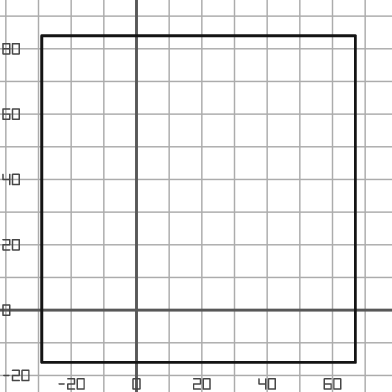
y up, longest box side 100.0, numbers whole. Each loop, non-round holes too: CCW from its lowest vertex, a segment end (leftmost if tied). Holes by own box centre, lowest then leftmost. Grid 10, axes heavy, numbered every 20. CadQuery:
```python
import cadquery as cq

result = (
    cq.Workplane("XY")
    .moveTo(-29.0, -16.0)
    .lineTo(67.0, -16.0)
    .lineTo(67.0, 84.0)
    .lineTo(-29.0, 84.0)
    .close()
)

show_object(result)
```